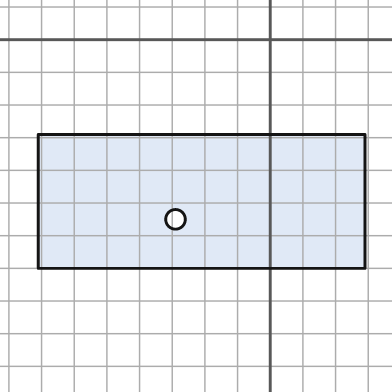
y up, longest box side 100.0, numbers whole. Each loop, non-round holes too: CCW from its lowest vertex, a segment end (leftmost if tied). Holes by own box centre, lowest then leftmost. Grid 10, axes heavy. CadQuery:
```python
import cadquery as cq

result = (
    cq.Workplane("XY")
    .moveTo(-71.0, -70.0)
    .lineTo(29.0, -70.0)
    .lineTo(29.0, -29.0)
    .lineTo(-71.0, -29.0)
    .close()
    .moveTo(-29.0, -55.0)
    .circle(3.0)
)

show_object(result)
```